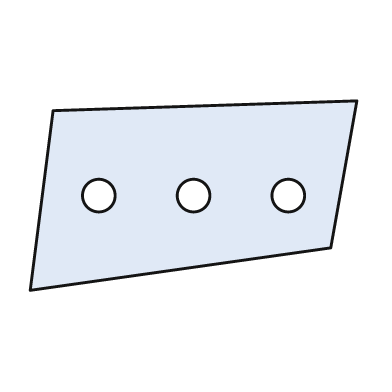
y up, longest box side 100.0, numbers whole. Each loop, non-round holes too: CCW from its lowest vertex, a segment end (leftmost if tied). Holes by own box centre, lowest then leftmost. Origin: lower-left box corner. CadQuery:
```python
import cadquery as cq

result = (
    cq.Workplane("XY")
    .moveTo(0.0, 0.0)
    .lineTo(92.0, 13.0)
    .lineTo(100.0, 58.0)
    .lineTo(7.0, 55.0)
    .close()
    .moveTo(21.0, 29.0)
    .circle(5.0)
    .moveTo(50.0, 29.0)
    .circle(5.0)
    .moveTo(79.0, 29.0)
    .circle(5.0)
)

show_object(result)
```